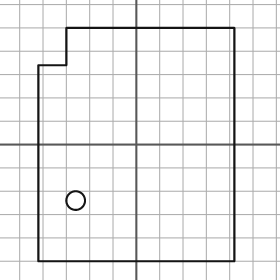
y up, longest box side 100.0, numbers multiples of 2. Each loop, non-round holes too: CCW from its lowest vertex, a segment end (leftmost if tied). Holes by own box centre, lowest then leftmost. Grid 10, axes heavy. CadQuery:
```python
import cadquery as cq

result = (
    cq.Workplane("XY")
    .moveTo(-42.0, -50.0)
    .lineTo(42.0, -50.0)
    .lineTo(42.0, 50.0)
    .lineTo(-30.0, 50.0)
    .lineTo(-30.0, 34.0)
    .lineTo(-42.0, 34.0)
    .close()
    .moveTo(-26.0, -24.0)
    .circle(4.0)
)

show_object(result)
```